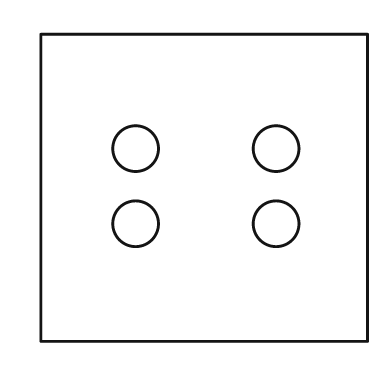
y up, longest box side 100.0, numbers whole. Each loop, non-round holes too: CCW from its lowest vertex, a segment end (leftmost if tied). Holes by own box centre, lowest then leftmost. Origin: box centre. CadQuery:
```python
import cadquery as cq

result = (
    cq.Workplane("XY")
    .moveTo(-50.0, -47.0)
    .lineTo(50.0, -47.0)
    .lineTo(50.0, 47.0)
    .lineTo(-50.0, 47.0)
    .close()
    .moveTo(-21.0, -11.0)
    .circle(7.0)
    .moveTo(22.0, -11.0)
    .circle(7.0)
    .moveTo(-21.0, 12.0)
    .circle(7.0)
    .moveTo(22.0, 12.0)
    .circle(7.0)
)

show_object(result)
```